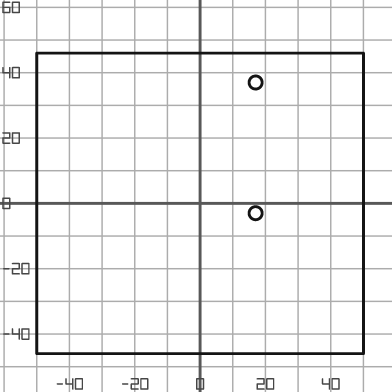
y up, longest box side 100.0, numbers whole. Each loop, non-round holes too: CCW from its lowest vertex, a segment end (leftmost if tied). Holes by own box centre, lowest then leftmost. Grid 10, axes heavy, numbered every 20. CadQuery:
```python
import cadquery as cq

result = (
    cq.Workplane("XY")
    .moveTo(-50.0, -46.0)
    .lineTo(50.0, -46.0)
    .lineTo(50.0, 46.0)
    .lineTo(-50.0, 46.0)
    .close()
    .moveTo(17.0, -3.0)
    .circle(2.0)
    .moveTo(17.0, 37.0)
    .circle(2.0)
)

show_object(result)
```